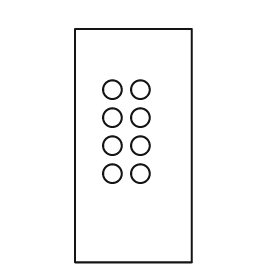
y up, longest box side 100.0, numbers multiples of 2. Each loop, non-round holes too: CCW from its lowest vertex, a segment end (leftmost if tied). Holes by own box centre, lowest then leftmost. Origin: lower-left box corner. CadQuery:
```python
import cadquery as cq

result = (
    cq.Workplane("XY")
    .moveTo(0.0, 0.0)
    .lineTo(50.0, 0.0)
    .lineTo(50.0, 100.0)
    .lineTo(0.0, 100.0)
    .close()
    .moveTo(16.0, 38.0)
    .circle(4.0)
    .moveTo(28.0, 38.0)
    .circle(4.0)
    .moveTo(16.0, 50.0)
    .circle(4.0)
    .moveTo(28.0, 50.0)
    .circle(4.0)
    .moveTo(16.0, 62.0)
    .circle(4.0)
    .moveTo(28.0, 62.0)
    .circle(4.0)
    .moveTo(16.0, 74.0)
    .circle(4.0)
    .moveTo(28.0, 74.0)
    .circle(4.0)
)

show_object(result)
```